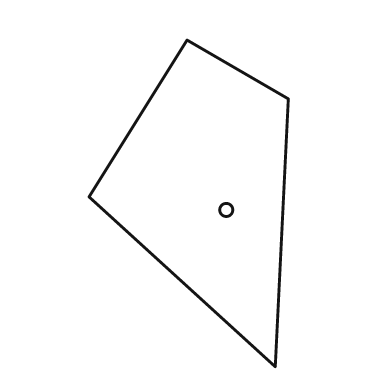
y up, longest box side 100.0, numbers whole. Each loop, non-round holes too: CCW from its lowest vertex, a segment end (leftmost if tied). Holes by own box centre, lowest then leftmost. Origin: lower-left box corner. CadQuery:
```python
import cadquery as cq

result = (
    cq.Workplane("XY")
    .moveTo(57.0, 0.0)
    .lineTo(61.0, 82.0)
    .lineTo(30.0, 100.0)
    .lineTo(0.0, 52.0)
    .close()
    .moveTo(42.0, 48.0)
    .circle(2.0)
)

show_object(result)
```